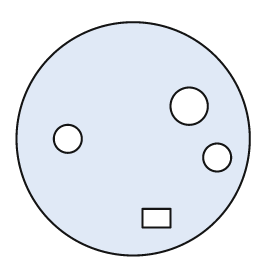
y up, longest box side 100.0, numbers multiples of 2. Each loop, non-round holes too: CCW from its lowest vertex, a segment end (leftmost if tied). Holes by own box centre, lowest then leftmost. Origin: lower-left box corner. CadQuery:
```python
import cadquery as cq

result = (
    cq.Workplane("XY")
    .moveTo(50.0, 50.0)
    .circle(50.0)
    .moveTo(54.0, 12.0)
    .lineTo(66.0, 12.0)
    .lineTo(66.0, 20.0)
    .lineTo(54.0, 20.0)
    .close()
    .moveTo(86.0, 42.0)
    .circle(6.0)
    .moveTo(22.0, 50.0)
    .circle(6.0)
    .moveTo(74.0, 64.0)
    .circle(8.0)
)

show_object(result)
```